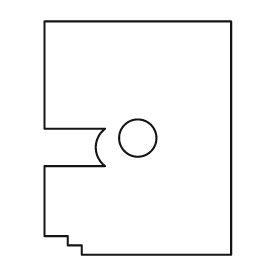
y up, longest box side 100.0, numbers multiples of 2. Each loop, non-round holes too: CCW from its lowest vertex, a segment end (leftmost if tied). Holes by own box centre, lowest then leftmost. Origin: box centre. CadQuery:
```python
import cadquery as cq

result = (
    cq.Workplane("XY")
    .moveTo(-24.0, -50.0)
    .lineTo(40.0, -50.0)
    .lineTo(40.0, 50.0)
    .lineTo(-40.0, 50.0)
    .lineTo(-40.0, 4.0)
    .lineTo(-14.0, 4.0)
    .threePointArc((-18.0, -4.0), (-14.0, -12.0))
    .lineTo(-40.0, -12.0)
    .lineTo(-40.0, -42.0)
    .lineTo(-30.0, -42.0)
    .lineTo(-30.0, -46.0)
    .lineTo(-24.0, -46.0)
    .close()
    .moveTo(0.0, 0.0)
    .circle(8.0)
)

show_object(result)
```